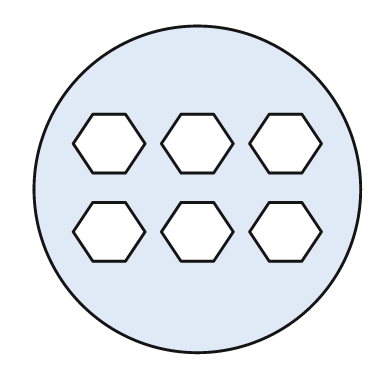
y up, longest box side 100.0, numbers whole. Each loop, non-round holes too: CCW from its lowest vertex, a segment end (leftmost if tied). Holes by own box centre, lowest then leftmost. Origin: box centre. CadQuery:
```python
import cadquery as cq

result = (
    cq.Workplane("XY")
    .moveTo(0.0, 0.0)
    .circle(50.0)
    .moveTo(-32.0, -22.0)
    .lineTo(-22.0, -22.0)
    .lineTo(-16.0, -13.0)
    .lineTo(-22.0, -4.0)
    .lineTo(-32.0, -4.0)
    .lineTo(-38.0, -13.0)
    .close()
    .moveTo(-5.0, -22.0)
    .lineTo(5.0, -22.0)
    .lineTo(11.0, -13.0)
    .lineTo(5.0, -4.0)
    .lineTo(-5.0, -4.0)
    .lineTo(-11.0, -13.0)
    .close()
    .moveTo(22.0, -22.0)
    .lineTo(32.0, -22.0)
    .lineTo(38.0, -13.0)
    .lineTo(32.0, -4.0)
    .lineTo(22.0, -4.0)
    .lineTo(16.0, -13.0)
    .close()
    .moveTo(-32.0, 5.0)
    .lineTo(-22.0, 5.0)
    .lineTo(-16.0, 14.0)
    .lineTo(-22.0, 23.0)
    .lineTo(-32.0, 23.0)
    .lineTo(-38.0, 14.0)
    .close()
    .moveTo(-5.0, 5.0)
    .lineTo(5.0, 5.0)
    .lineTo(11.0, 14.0)
    .lineTo(5.0, 23.0)
    .lineTo(-5.0, 23.0)
    .lineTo(-11.0, 14.0)
    .close()
    .moveTo(22.0, 5.0)
    .lineTo(32.0, 5.0)
    .lineTo(38.0, 14.0)
    .lineTo(32.0, 23.0)
    .lineTo(22.0, 23.0)
    .lineTo(16.0, 14.0)
    .close()
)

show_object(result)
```